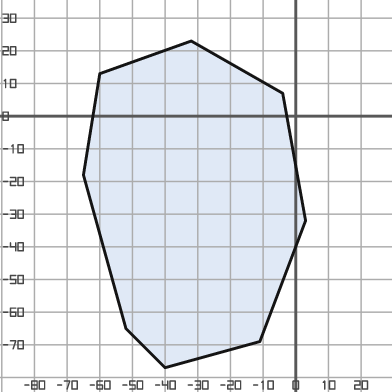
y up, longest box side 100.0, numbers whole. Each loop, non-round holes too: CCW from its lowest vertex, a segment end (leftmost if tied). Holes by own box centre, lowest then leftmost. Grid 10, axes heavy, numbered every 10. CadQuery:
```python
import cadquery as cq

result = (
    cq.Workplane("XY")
    .moveTo(-40.0, -77.0)
    .lineTo(-11.0, -69.0)
    .lineTo(3.0, -32.0)
    .lineTo(-4.0, 7.0)
    .lineTo(-32.0, 23.0)
    .lineTo(-60.0, 13.0)
    .lineTo(-65.0, -18.0)
    .lineTo(-52.0, -65.0)
    .close()
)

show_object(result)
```